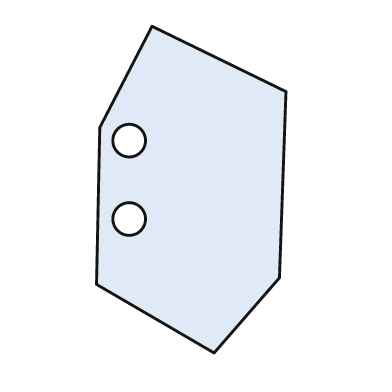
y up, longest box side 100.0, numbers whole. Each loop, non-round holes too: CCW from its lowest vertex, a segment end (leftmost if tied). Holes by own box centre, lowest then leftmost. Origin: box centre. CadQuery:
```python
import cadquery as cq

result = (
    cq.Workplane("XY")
    .moveTo(7.0, -50.0)
    .lineTo(27.0, -27.0)
    .lineTo(29.0, 30.0)
    .lineTo(-12.0, 50.0)
    .lineTo(-28.0, 19.0)
    .lineTo(-29.0, -29.0)
    .close()
    .moveTo(-19.0, -9.0)
    .circle(5.0)
    .moveTo(-19.0, 15.0)
    .circle(5.0)
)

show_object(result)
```